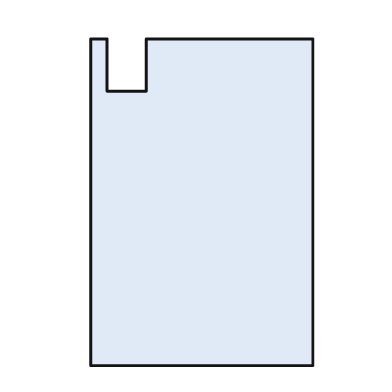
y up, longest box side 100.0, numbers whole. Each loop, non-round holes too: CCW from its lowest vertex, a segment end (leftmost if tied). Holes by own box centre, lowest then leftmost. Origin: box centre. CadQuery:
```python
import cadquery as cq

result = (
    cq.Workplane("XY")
    .moveTo(-34.0, -50.0)
    .lineTo(34.0, -50.0)
    .lineTo(34.0, 50.0)
    .lineTo(-17.0, 50.0)
    .lineTo(-17.0, 34.0)
    .lineTo(-29.0, 34.0)
    .lineTo(-29.0, 50.0)
    .lineTo(-34.0, 50.0)
    .close()
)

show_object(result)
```